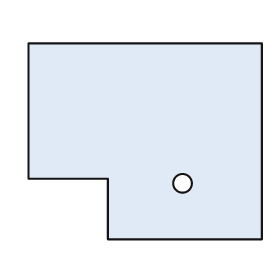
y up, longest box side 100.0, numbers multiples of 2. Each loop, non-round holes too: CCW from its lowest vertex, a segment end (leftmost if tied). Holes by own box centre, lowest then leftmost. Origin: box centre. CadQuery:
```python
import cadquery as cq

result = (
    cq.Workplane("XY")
    .moveTo(-16.0, -42.0)
    .lineTo(50.0, -42.0)
    .lineTo(50.0, 42.0)
    .lineTo(-50.0, 42.0)
    .lineTo(-50.0, -16.0)
    .lineTo(-16.0, -16.0)
    .close()
    .moveTo(16.0, -18.0)
    .circle(4.0)
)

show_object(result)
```